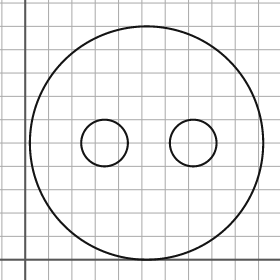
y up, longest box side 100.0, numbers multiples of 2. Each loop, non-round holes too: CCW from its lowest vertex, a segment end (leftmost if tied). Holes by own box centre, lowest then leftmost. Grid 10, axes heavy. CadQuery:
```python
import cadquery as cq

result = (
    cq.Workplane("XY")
    .moveTo(52.0, 50.0)
    .circle(50.0)
    .moveTo(34.0, 50.0)
    .circle(10.0)
    .moveTo(72.0, 50.0)
    .circle(10.0)
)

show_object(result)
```